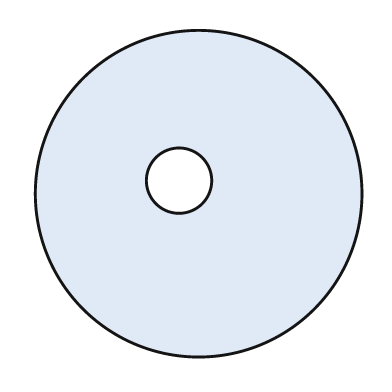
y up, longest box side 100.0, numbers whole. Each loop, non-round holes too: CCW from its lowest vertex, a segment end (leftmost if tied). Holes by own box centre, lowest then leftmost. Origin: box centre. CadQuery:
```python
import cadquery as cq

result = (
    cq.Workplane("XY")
    .moveTo(0.0, 0.0)
    .circle(50.0)
    .moveTo(-6.0, 4.0)
    .circle(10.0)
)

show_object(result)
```